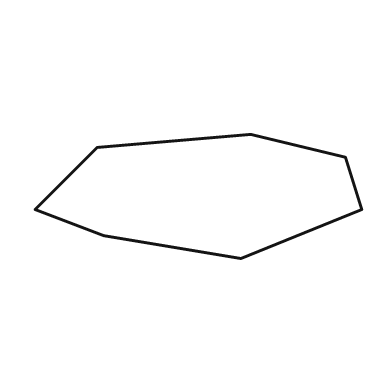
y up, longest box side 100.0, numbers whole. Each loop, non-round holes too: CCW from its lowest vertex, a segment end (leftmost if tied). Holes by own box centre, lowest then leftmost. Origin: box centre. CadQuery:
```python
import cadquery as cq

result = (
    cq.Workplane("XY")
    .moveTo(13.0, -19.0)
    .lineTo(50.0, -4.0)
    .lineTo(45.0, 12.0)
    .lineTo(16.0, 19.0)
    .lineTo(-31.0, 15.0)
    .lineTo(-50.0, -4.0)
    .lineTo(-29.0, -12.0)
    .close()
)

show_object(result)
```